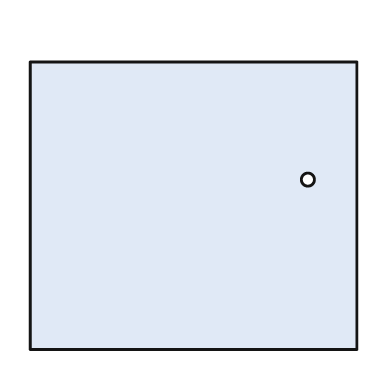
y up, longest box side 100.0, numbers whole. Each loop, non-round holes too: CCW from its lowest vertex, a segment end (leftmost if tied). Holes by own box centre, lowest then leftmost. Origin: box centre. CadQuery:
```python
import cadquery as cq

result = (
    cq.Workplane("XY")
    .moveTo(-50.0, -44.0)
    .lineTo(50.0, -44.0)
    .lineTo(50.0, 44.0)
    .lineTo(-50.0, 44.0)
    .close()
    .moveTo(35.0, 8.0)
    .circle(2.0)
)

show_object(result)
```